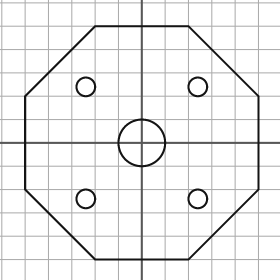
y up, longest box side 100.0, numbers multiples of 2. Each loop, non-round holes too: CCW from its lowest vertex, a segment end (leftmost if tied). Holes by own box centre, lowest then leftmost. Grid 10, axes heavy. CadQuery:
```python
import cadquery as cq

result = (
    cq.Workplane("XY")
    .moveTo(-20.0, -50.0)
    .lineTo(20.0, -50.0)
    .lineTo(50.0, -20.0)
    .lineTo(50.0, 20.0)
    .lineTo(20.0, 50.0)
    .lineTo(-20.0, 50.0)
    .lineTo(-50.0, 20.0)
    .lineTo(-50.0, -20.0)
    .close()
    .moveTo(-24.0, -24.0)
    .circle(4.0)
    .moveTo(24.0, -24.0)
    .circle(4.0)
    .moveTo(0.0, 0.0)
    .circle(10.0)
    .moveTo(-24.0, 24.0)
    .circle(4.0)
    .moveTo(24.0, 24.0)
    .circle(4.0)
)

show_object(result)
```